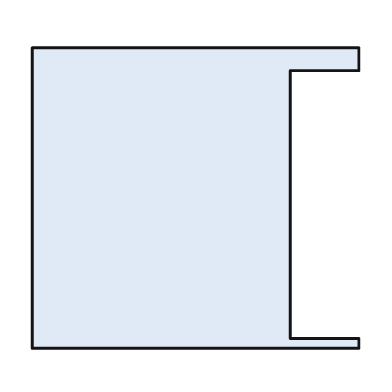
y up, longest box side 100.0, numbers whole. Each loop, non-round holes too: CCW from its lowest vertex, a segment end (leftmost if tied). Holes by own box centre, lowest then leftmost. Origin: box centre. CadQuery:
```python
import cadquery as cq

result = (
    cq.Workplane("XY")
    .moveTo(-50.0, -46.0)
    .lineTo(50.0, -46.0)
    .lineTo(50.0, -43.0)
    .lineTo(29.0, -43.0)
    .lineTo(29.0, 39.0)
    .lineTo(50.0, 39.0)
    .lineTo(50.0, 46.0)
    .lineTo(-50.0, 46.0)
    .close()
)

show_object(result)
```